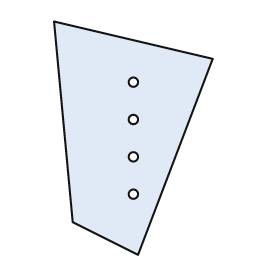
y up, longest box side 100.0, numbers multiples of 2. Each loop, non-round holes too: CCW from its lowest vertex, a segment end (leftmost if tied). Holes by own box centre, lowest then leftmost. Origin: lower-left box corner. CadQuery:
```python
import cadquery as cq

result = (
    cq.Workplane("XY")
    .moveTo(36.0, 0.0)
    .lineTo(68.0, 84.0)
    .lineTo(0.0, 100.0)
    .lineTo(8.0, 14.0)
    .close()
    .moveTo(34.0, 26.0)
    .circle(2.0)
    .moveTo(34.0, 42.0)
    .circle(2.0)
    .moveTo(34.0, 58.0)
    .circle(2.0)
    .moveTo(34.0, 74.0)
    .circle(2.0)
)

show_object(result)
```